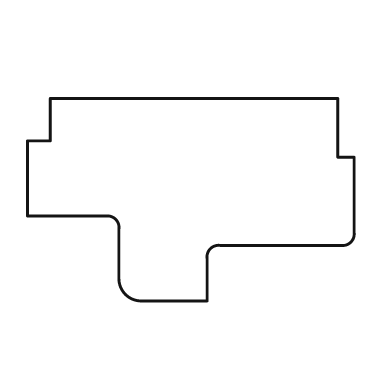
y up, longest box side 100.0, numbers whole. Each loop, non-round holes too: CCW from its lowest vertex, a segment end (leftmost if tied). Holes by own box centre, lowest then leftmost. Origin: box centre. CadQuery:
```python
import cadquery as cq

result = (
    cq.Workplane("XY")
    .moveTo(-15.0, -31.0)
    .lineTo(5.0, -31.0)
    .lineTo(5.0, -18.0)
    .threePointArc((6.0, -15.0), (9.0, -14.0))
    .lineTo(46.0, -14.0)
    .threePointArc((49.0, -13.0), (50.0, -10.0))
    .lineTo(50.0, 13.0)
    .lineTo(45.0, 13.0)
    .lineTo(45.0, 31.0)
    .lineTo(-43.0, 31.0)
    .lineTo(-43.0, 18.0)
    .lineTo(-50.0, 18.0)
    .lineTo(-50.0, -5.0)
    .lineTo(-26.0, -5.0)
    .threePointArc((-23.0, -6.0), (-22.0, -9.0))
    .lineTo(-22.0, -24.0)
    .threePointArc((-20.0, -29.0), (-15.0, -31.0))
    .close()
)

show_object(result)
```